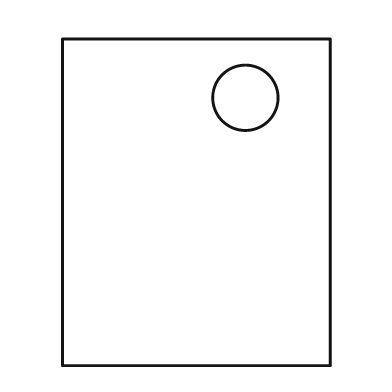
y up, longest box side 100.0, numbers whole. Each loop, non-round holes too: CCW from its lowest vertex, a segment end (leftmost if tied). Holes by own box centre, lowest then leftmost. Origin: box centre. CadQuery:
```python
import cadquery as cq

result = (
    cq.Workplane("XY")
    .moveTo(-41.0, -50.0)
    .lineTo(41.0, -50.0)
    .lineTo(41.0, 50.0)
    .lineTo(-41.0, 50.0)
    .close()
    .moveTo(15.0, 32.0)
    .circle(10.0)
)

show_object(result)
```